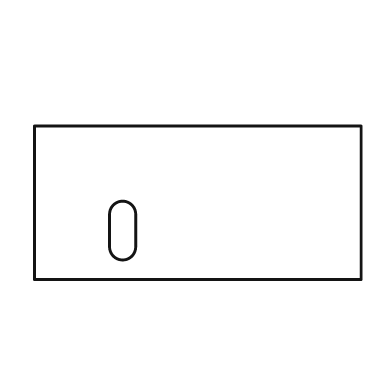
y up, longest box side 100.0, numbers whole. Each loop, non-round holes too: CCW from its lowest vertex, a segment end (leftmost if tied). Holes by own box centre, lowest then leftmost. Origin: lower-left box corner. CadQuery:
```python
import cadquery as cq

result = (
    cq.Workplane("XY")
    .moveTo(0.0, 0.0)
    .lineTo(100.0, 0.0)
    .lineTo(100.0, 47.0)
    .lineTo(0.0, 47.0)
    .close()
    .moveTo(23.0, 10.0)
    .threePointArc((27.0, 6.0), (31.0, 10.0))
    .lineTo(31.0, 20.0)
    .threePointArc((27.0, 24.0), (23.0, 20.0))
    .close()
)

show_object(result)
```